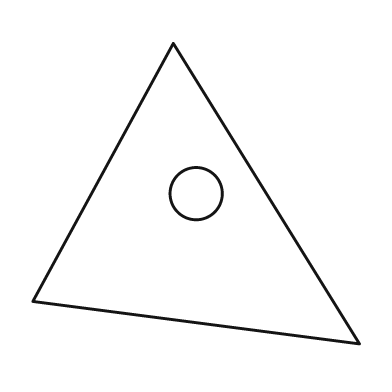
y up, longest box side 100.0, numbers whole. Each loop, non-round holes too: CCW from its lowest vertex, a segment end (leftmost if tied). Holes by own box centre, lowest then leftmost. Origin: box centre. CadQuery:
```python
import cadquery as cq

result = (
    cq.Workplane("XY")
    .moveTo(50.0, -46.0)
    .lineTo(-7.0, 46.0)
    .lineTo(-50.0, -33.0)
    .close()
    .moveTo(0.0, 0.0)
    .circle(8.0)
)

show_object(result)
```